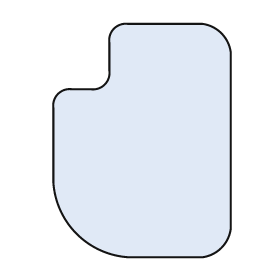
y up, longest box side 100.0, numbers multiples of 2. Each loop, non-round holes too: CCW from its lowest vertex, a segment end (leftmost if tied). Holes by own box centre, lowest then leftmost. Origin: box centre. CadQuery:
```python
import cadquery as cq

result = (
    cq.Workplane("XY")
    .moveTo(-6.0, -50.0)
    .lineTo(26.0, -50.0)
    .threePointArc((34.0, -46.0), (38.0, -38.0))
    .lineTo(38.0, 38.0)
    .threePointArc((34.0, 46.0), (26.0, 50.0))
    .lineTo(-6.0, 50.0)
    .threePointArc((-12.0, 48.0), (-14.0, 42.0))
    .lineTo(-14.0, 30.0)
    .threePointArc((-16.0, 24.0), (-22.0, 22.0))
    .lineTo(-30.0, 22.0)
    .threePointArc((-36.0, 20.0), (-38.0, 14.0))
    .lineTo(-38.0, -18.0)
    .threePointArc((-28.0, -40.0), (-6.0, -50.0))
    .close()
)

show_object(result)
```